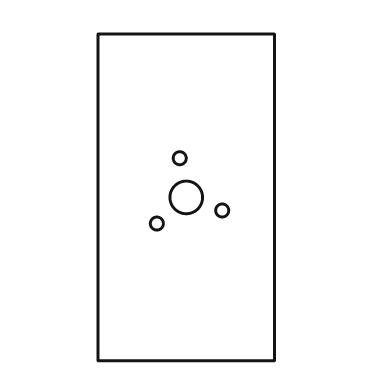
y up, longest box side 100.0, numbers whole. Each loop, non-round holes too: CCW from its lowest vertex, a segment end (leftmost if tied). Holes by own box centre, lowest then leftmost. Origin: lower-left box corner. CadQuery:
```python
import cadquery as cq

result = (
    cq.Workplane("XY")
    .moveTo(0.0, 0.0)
    .lineTo(54.0, 0.0)
    .lineTo(54.0, 100.0)
    .lineTo(0.0, 100.0)
    .close()
    .moveTo(18.0, 42.0)
    .circle(2.0)
    .moveTo(38.0, 46.0)
    .circle(2.0)
    .moveTo(27.0, 50.0)
    .circle(5.0)
    .moveTo(25.0, 62.0)
    .circle(2.0)
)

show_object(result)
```